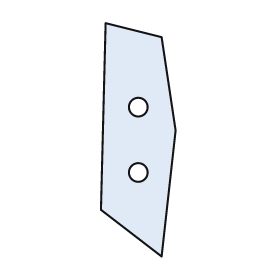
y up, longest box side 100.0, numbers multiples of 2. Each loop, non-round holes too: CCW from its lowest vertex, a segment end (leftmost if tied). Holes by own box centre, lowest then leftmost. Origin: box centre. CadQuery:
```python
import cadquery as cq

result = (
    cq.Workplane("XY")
    .moveTo(10.0, -50.0)
    .lineTo(16.0, 4.0)
    .lineTo(10.0, 44.0)
    .lineTo(-14.0, 50.0)
    .lineTo(-16.0, -30.0)
    .close()
    .moveTo(0.0, -14.0)
    .circle(4.0)
    .moveTo(0.0, 14.0)
    .circle(4.0)
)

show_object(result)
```